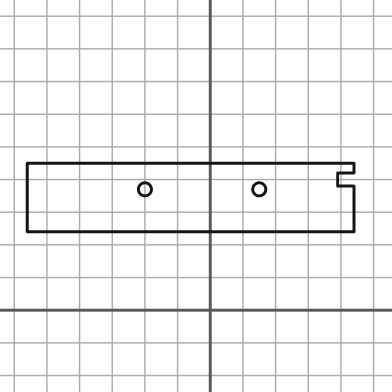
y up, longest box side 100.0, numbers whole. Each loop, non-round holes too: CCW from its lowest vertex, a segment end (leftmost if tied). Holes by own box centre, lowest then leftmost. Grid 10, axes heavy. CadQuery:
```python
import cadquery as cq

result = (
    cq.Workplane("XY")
    .moveTo(-56.0, 24.0)
    .lineTo(44.0, 24.0)
    .lineTo(44.0, 38.0)
    .lineTo(39.0, 38.0)
    .lineTo(39.0, 42.0)
    .lineTo(44.0, 42.0)
    .lineTo(44.0, 45.0)
    .lineTo(-56.0, 45.0)
    .close()
    .moveTo(-20.0, 37.0)
    .circle(2.0)
    .moveTo(15.0, 37.0)
    .circle(2.0)
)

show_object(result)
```